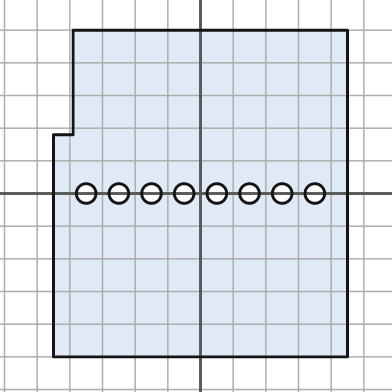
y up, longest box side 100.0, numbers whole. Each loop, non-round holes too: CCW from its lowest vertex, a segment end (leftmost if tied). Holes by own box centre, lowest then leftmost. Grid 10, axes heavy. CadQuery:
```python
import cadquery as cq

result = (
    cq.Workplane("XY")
    .moveTo(-45.0, -50.0)
    .lineTo(45.0, -50.0)
    .lineTo(45.0, 50.0)
    .lineTo(-39.0, 50.0)
    .lineTo(-39.0, 18.0)
    .lineTo(-45.0, 18.0)
    .close()
    .moveTo(-35.0, 0.0)
    .circle(3.0)
    .moveTo(-25.0, 0.0)
    .circle(3.0)
    .moveTo(-15.0, 0.0)
    .circle(3.0)
    .moveTo(-5.0, 0.0)
    .circle(3.0)
    .moveTo(5.0, 0.0)
    .circle(3.0)
    .moveTo(15.0, 0.0)
    .circle(3.0)
    .moveTo(25.0, 0.0)
    .circle(3.0)
    .moveTo(35.0, 0.0)
    .circle(3.0)
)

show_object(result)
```